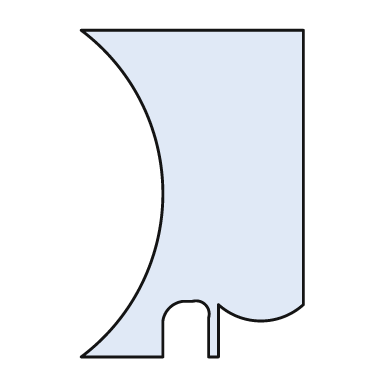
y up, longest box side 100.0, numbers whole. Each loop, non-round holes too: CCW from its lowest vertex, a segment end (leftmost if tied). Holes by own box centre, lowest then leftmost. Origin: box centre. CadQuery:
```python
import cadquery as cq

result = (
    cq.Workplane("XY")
    .moveTo(-34.0, -50.0)
    .lineTo(-9.0, -50.0)
    .lineTo(-9.0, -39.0)
    .threePointArc((-7.0, -35.0), (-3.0, -33.0))
    .lineTo(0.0, -33.0)
    .threePointArc((4.0, -34.0), (5.0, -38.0))
    .lineTo(5.0, -50.0)
    .lineTo(8.0, -50.0)
    .lineTo(8.0, -34.0)
    .threePointArc((21.0, -39.0), (34.0, -34.0))
    .lineTo(34.0, 50.0)
    .lineTo(-34.0, 50.0)
    .threePointArc((-9.0, 0.0), (-34.0, -50.0))
    .close()
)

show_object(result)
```